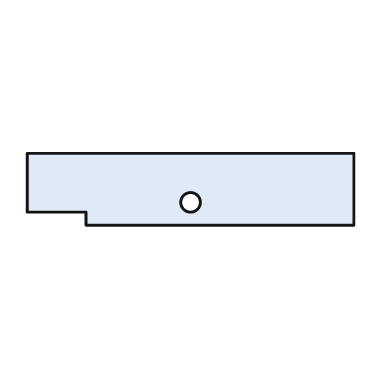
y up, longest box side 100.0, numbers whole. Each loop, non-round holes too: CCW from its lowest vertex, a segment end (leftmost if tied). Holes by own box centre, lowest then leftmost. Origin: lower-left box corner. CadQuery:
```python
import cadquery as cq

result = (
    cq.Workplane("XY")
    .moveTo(18.0, 0.0)
    .lineTo(100.0, 0.0)
    .lineTo(100.0, 22.0)
    .lineTo(0.0, 22.0)
    .lineTo(0.0, 4.0)
    .lineTo(18.0, 4.0)
    .close()
    .moveTo(50.0, 7.0)
    .circle(3.0)
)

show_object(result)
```